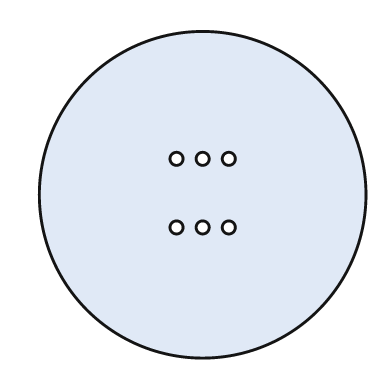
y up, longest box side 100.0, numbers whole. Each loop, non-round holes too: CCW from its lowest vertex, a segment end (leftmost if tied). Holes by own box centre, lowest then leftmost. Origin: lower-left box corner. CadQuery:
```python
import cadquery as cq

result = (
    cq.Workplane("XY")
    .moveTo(50.0, 50.0)
    .circle(50.0)
    .moveTo(42.0, 40.0)
    .circle(2.0)
    .moveTo(50.0, 40.0)
    .circle(2.0)
    .moveTo(58.0, 40.0)
    .circle(2.0)
    .moveTo(42.0, 61.0)
    .circle(2.0)
    .moveTo(50.0, 61.0)
    .circle(2.0)
    .moveTo(58.0, 61.0)
    .circle(2.0)
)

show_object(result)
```